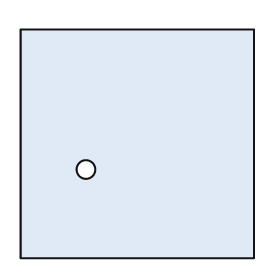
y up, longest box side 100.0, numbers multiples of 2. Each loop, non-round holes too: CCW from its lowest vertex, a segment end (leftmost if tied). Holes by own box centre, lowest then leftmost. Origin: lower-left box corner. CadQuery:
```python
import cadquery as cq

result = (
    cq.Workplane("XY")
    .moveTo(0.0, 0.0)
    .lineTo(100.0, 0.0)
    .lineTo(100.0, 98.0)
    .lineTo(0.0, 98.0)
    .close()
    .moveTo(28.0, 38.0)
    .circle(4.0)
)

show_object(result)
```